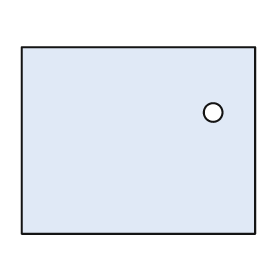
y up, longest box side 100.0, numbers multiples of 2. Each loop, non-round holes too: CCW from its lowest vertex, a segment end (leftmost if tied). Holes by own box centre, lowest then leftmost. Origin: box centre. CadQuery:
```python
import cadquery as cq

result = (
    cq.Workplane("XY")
    .moveTo(-50.0, -40.0)
    .lineTo(50.0, -40.0)
    .lineTo(50.0, 40.0)
    .lineTo(-50.0, 40.0)
    .close()
    .moveTo(32.0, 12.0)
    .circle(4.0)
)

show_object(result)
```